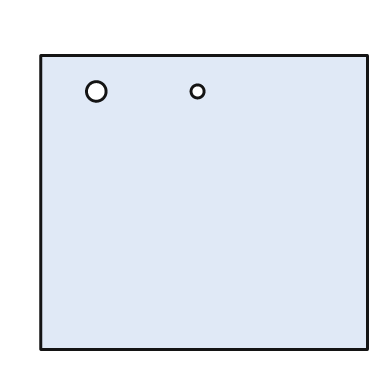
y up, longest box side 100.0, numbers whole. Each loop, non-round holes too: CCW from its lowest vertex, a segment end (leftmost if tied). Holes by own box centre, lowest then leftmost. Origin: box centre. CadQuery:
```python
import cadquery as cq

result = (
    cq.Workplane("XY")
    .moveTo(-50.0, -45.0)
    .lineTo(50.0, -45.0)
    .lineTo(50.0, 45.0)
    .lineTo(-50.0, 45.0)
    .close()
    .moveTo(-33.0, 34.0)
    .circle(3.0)
    .moveTo(-2.0, 34.0)
    .circle(2.0)
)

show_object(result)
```